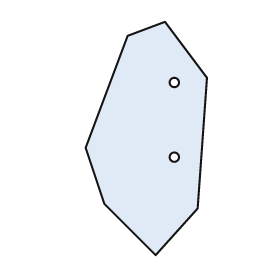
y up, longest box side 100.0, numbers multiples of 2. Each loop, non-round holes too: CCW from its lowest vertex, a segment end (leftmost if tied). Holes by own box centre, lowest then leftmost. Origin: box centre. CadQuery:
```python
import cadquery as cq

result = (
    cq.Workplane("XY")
    .moveTo(4.0, -50.0)
    .lineTo(22.0, -30.0)
    .lineTo(26.0, 26.0)
    .lineTo(8.0, 50.0)
    .lineTo(-8.0, 44.0)
    .lineTo(-26.0, -4.0)
    .lineTo(-18.0, -28.0)
    .close()
    .moveTo(12.0, -8.0)
    .circle(2.0)
    .moveTo(12.0, 24.0)
    .circle(2.0)
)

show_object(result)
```